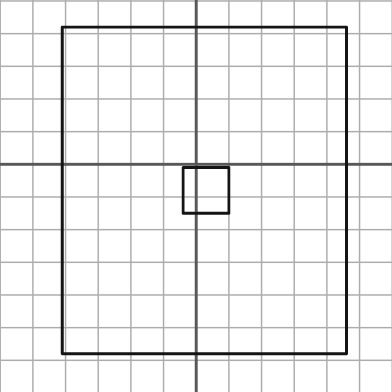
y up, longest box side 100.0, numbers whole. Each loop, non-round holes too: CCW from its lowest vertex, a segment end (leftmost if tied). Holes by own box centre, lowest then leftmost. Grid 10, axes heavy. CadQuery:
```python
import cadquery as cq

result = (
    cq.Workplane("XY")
    .moveTo(-41.0, -58.0)
    .lineTo(46.0, -58.0)
    .lineTo(46.0, 42.0)
    .lineTo(-41.0, 42.0)
    .close()
    .moveTo(-4.0, -15.0)
    .lineTo(10.0, -15.0)
    .lineTo(10.0, -1.0)
    .lineTo(-4.0, -1.0)
    .close()
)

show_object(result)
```